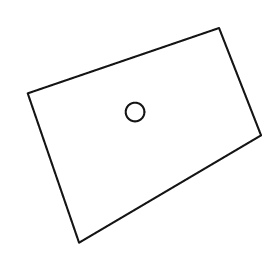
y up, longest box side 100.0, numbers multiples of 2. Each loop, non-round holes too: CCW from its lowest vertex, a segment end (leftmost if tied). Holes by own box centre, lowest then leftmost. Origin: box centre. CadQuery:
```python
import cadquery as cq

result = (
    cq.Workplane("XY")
    .moveTo(-28.0, -46.0)
    .lineTo(50.0, 0.0)
    .lineTo(32.0, 46.0)
    .lineTo(-50.0, 18.0)
    .close()
    .moveTo(-4.0, 10.0)
    .circle(4.0)
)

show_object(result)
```